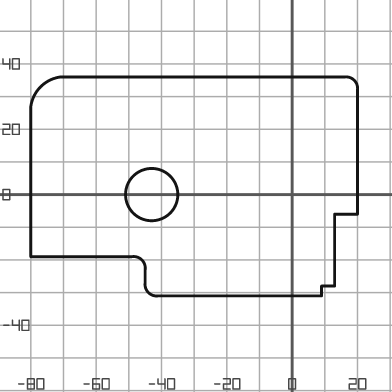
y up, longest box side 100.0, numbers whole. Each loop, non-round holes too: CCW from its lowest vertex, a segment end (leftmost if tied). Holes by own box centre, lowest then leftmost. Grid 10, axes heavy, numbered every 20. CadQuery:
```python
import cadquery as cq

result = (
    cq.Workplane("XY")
    .moveTo(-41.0, -31.0)
    .lineTo(9.0, -31.0)
    .lineTo(9.0, -28.0)
    .lineTo(13.0, -28.0)
    .lineTo(13.0, -6.0)
    .lineTo(20.0, -6.0)
    .lineTo(20.0, 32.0)
    .threePointArc((19.0, 35.0), (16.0, 36.0))
    .lineTo(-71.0, 36.0)
    .threePointArc((-77.0, 33.0), (-80.0, 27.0))
    .lineTo(-80.0, -19.0)
    .lineTo(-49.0, -19.0)
    .threePointArc((-46.0, -20.0), (-45.0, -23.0))
    .lineTo(-45.0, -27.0)
    .threePointArc((-44.0, -30.0), (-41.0, -31.0))
    .close()
    .moveTo(-43.0, 0.0)
    .circle(8.0)
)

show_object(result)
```